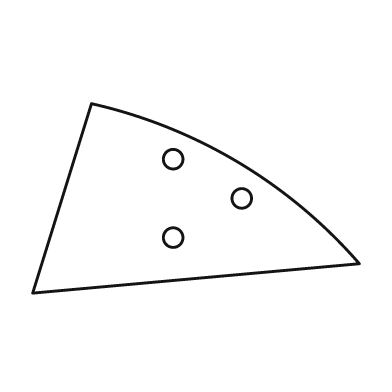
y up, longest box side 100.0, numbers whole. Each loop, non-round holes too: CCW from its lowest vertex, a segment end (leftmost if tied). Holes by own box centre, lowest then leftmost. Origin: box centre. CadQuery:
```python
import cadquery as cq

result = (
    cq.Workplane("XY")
    .moveTo(-50.0, -29.0)
    .lineTo(50.0, -20.0)
    .threePointArc((13.0, 11.0), (-32.0, 29.0))
    .close()
    .moveTo(-7.0, -12.0)
    .circle(3.0)
    .moveTo(14.0, 0.0)
    .circle(3.0)
    .moveTo(-7.0, 12.0)
    .circle(3.0)
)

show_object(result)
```